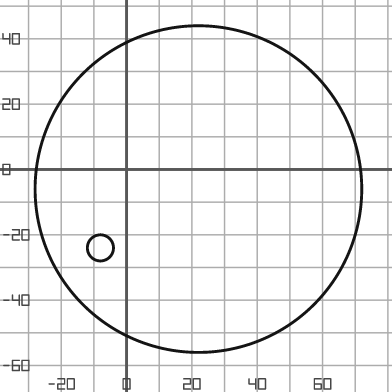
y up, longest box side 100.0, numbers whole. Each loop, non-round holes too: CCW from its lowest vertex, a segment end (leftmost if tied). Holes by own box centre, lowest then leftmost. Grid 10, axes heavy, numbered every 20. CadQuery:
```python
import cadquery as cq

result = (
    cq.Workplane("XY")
    .moveTo(22.0, -6.0)
    .circle(50.0)
    .moveTo(-8.0, -24.0)
    .circle(4.0)
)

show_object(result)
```